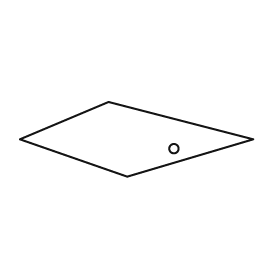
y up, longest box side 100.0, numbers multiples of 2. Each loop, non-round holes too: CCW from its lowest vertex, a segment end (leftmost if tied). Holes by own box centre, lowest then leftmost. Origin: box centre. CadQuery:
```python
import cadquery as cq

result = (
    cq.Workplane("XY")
    .moveTo(-4.0, -16.0)
    .lineTo(50.0, 0.0)
    .lineTo(-12.0, 16.0)
    .lineTo(-50.0, 0.0)
    .close()
    .moveTo(16.0, -4.0)
    .circle(2.0)
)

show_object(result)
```